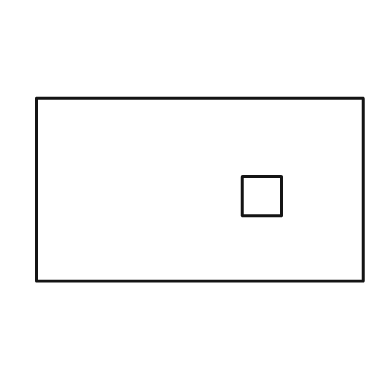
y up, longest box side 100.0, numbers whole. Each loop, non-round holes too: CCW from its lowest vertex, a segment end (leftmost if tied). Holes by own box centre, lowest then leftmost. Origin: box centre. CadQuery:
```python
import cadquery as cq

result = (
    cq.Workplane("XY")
    .moveTo(-50.0, -28.0)
    .lineTo(50.0, -28.0)
    .lineTo(50.0, 28.0)
    .lineTo(-50.0, 28.0)
    .close()
    .moveTo(13.0, -8.0)
    .lineTo(25.0, -8.0)
    .lineTo(25.0, 4.0)
    .lineTo(13.0, 4.0)
    .close()
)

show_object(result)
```